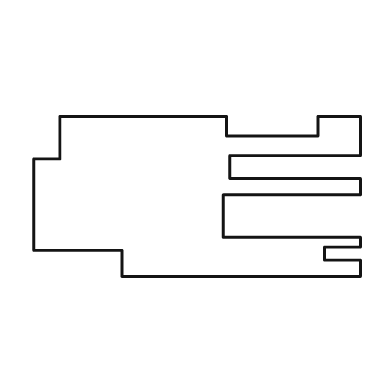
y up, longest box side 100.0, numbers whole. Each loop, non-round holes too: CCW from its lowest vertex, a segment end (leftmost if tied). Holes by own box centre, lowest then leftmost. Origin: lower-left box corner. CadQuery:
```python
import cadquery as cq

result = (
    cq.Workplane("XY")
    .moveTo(27.0, 0.0)
    .lineTo(100.0, 0.0)
    .lineTo(100.0, 5.0)
    .lineTo(89.0, 5.0)
    .lineTo(89.0, 9.0)
    .lineTo(100.0, 9.0)
    .lineTo(100.0, 12.0)
    .lineTo(58.0, 12.0)
    .lineTo(58.0, 25.0)
    .lineTo(100.0, 25.0)
    .lineTo(100.0, 30.0)
    .lineTo(60.0, 30.0)
    .lineTo(60.0, 37.0)
    .lineTo(100.0, 37.0)
    .lineTo(100.0, 49.0)
    .lineTo(87.0, 49.0)
    .lineTo(87.0, 43.0)
    .lineTo(59.0, 43.0)
    .lineTo(59.0, 49.0)
    .lineTo(8.0, 49.0)
    .lineTo(8.0, 36.0)
    .lineTo(0.0, 36.0)
    .lineTo(0.0, 8.0)
    .lineTo(27.0, 8.0)
    .close()
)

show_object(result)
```